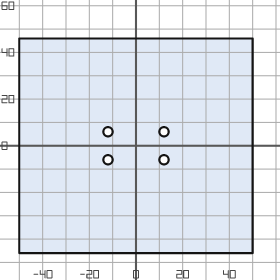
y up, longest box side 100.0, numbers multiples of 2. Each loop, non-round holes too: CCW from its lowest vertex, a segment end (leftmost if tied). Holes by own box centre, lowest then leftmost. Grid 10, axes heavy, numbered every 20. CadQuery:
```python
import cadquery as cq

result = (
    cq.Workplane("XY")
    .moveTo(-50.0, -46.0)
    .lineTo(50.0, -46.0)
    .lineTo(50.0, 46.0)
    .lineTo(-50.0, 46.0)
    .close()
    .moveTo(-12.0, -6.0)
    .circle(2.0)
    .moveTo(12.0, -6.0)
    .circle(2.0)
    .moveTo(-12.0, 6.0)
    .circle(2.0)
    .moveTo(12.0, 6.0)
    .circle(2.0)
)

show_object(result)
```